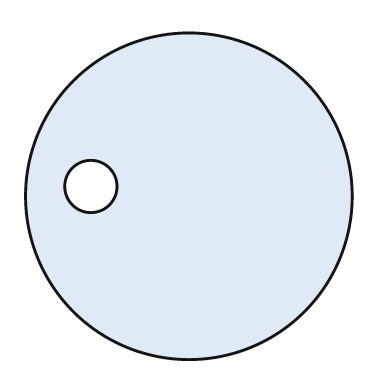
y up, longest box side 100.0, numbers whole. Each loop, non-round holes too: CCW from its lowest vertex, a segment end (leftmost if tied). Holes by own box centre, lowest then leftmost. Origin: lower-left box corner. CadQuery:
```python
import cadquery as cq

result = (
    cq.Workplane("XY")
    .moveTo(50.0, 50.0)
    .circle(50.0)
    .moveTo(20.0, 53.0)
    .circle(8.0)
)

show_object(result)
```